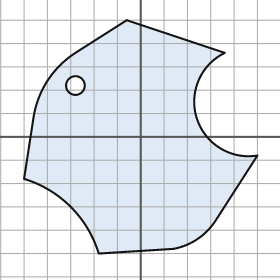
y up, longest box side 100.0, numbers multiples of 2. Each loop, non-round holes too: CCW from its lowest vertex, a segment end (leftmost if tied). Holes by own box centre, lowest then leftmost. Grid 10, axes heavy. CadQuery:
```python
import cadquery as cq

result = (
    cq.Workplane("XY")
    .moveTo(-18.0, -50.0)
    .lineTo(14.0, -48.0)
    .threePointArc((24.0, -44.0), (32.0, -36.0))
    .lineTo(50.0, -8.0)
    .threePointArc((24.0, 8.0), (36.0, 36.0))
    .lineTo(-6.0, 50.0)
    .lineTo(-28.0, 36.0)
    .threePointArc((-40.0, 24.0), (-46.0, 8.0))
    .lineTo(-50.0, -18.0)
    .threePointArc((-30.0, -30.0), (-18.0, -50.0))
    .close()
    .moveTo(-28.0, 22.0)
    .circle(4.0)
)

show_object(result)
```